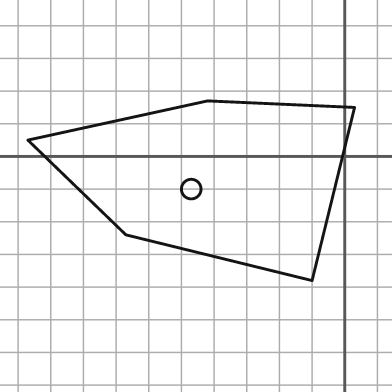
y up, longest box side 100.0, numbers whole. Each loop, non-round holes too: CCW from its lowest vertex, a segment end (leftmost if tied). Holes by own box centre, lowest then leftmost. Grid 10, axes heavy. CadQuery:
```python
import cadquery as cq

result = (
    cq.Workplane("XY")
    .moveTo(-10.0, -38.0)
    .lineTo(3.0, 15.0)
    .lineTo(-42.0, 17.0)
    .lineTo(-97.0, 5.0)
    .lineTo(-67.0, -24.0)
    .close()
    .moveTo(-47.0, -10.0)
    .circle(3.0)
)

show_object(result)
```